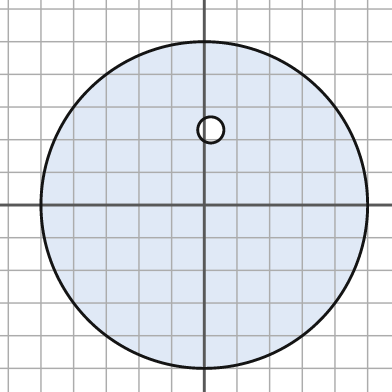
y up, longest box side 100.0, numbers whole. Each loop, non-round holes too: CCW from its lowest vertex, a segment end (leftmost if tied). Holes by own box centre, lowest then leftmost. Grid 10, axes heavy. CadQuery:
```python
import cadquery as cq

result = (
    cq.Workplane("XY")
    .moveTo(0.0, 0.0)
    .circle(50.0)
    .moveTo(2.0, 23.0)
    .circle(4.0)
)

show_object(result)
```